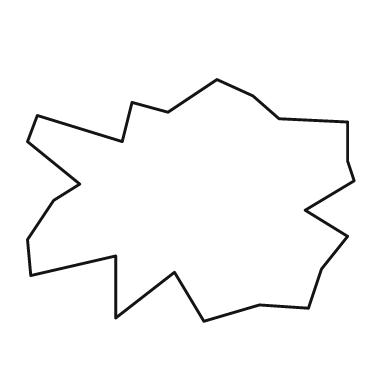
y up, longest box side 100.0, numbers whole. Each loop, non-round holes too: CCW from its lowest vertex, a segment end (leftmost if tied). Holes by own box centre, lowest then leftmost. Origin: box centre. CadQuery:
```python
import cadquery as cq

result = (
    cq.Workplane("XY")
    .moveTo(4.0, -37.0)
    .lineTo(21.0, -32.0)
    .lineTo(36.0, -33.0)
    .lineTo(40.0, -21.0)
    .lineTo(48.0, -11.0)
    .lineTo(35.0, -3.0)
    .lineTo(50.0, 6.0)
    .lineTo(48.0, 12.0)
    .lineTo(48.0, 24.0)
    .lineTo(27.0, 25.0)
    .lineTo(19.0, 32.0)
    .lineTo(8.0, 37.0)
    .lineTo(-7.0, 27.0)
    .lineTo(-18.0, 30.0)
    .lineTo(-21.0, 18.0)
    .lineTo(-47.0, 26.0)
    .lineTo(-50.0, 18.0)
    .lineTo(-34.0, 5.0)
    .lineTo(-42.0, 0.0)
    .lineTo(-50.0, -12.0)
    .lineTo(-49.0, -23.0)
    .lineTo(-23.0, -17.0)
    .lineTo(-23.0, -36.0)
    .lineTo(-5.0, -22.0)
    .close()
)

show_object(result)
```